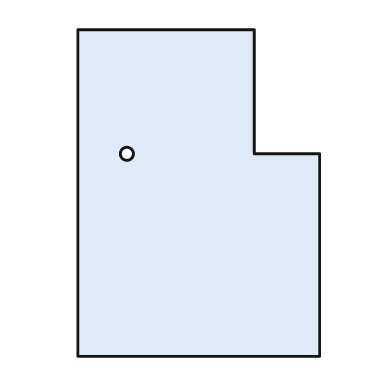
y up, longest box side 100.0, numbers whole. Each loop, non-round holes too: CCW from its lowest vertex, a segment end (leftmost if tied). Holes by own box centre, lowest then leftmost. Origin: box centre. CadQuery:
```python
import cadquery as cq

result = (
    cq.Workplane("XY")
    .moveTo(-37.0, -50.0)
    .lineTo(37.0, -50.0)
    .lineTo(37.0, 12.0)
    .lineTo(17.0, 12.0)
    .lineTo(17.0, 50.0)
    .lineTo(-37.0, 50.0)
    .close()
    .moveTo(-22.0, 12.0)
    .circle(2.0)
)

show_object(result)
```